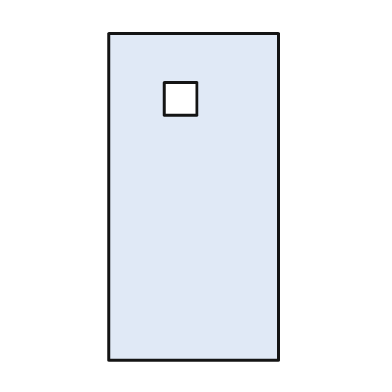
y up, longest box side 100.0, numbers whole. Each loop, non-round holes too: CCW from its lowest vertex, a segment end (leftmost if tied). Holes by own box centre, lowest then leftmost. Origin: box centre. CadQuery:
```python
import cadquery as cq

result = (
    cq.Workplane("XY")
    .moveTo(-26.0, -50.0)
    .lineTo(26.0, -50.0)
    .lineTo(26.0, 50.0)
    .lineTo(-26.0, 50.0)
    .close()
    .moveTo(-9.0, 25.0)
    .lineTo(1.0, 25.0)
    .lineTo(1.0, 35.0)
    .lineTo(-9.0, 35.0)
    .close()
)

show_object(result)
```